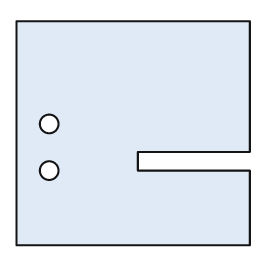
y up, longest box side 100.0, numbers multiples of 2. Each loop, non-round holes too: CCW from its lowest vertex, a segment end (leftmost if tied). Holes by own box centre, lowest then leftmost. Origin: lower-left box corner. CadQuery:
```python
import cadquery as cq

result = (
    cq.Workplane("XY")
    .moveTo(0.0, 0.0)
    .lineTo(100.0, 0.0)
    .lineTo(100.0, 32.0)
    .lineTo(52.0, 32.0)
    .lineTo(52.0, 40.0)
    .lineTo(100.0, 40.0)
    .lineTo(100.0, 96.0)
    .lineTo(0.0, 96.0)
    .close()
    .moveTo(14.0, 32.0)
    .circle(4.0)
    .moveTo(14.0, 52.0)
    .circle(4.0)
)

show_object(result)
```